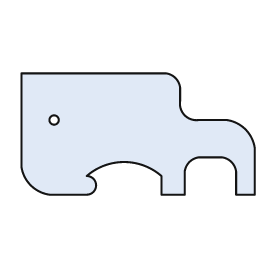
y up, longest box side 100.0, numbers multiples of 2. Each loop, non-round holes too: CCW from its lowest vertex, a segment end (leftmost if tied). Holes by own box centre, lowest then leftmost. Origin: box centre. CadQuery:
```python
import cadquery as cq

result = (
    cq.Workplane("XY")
    .moveTo(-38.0, -26.0)
    .lineTo(-22.0, -26.0)
    .threePointArc((-18.0, -22.0), (-22.0, -18.0))
    .threePointArc((-6.0, -12.0), (10.0, -18.0))
    .lineTo(10.0, -26.0)
    .lineTo(20.0, -26.0)
    .lineTo(20.0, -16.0)
    .threePointArc((22.0, -12.0), (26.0, -10.0))
    .lineTo(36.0, -10.0)
    .threePointArc((40.0, -12.0), (42.0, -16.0))
    .lineTo(42.0, -26.0)
    .lineTo(50.0, -26.0)
    .lineTo(50.0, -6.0)
    .threePointArc((46.0, 2.0), (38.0, 6.0))
    .lineTo(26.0, 6.0)
    .threePointArc((20.0, 8.0), (18.0, 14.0))
    .lineTo(18.0, 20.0)
    .threePointArc((16.0, 24.0), (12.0, 26.0))
    .lineTo(-50.0, 26.0)
    .lineTo(-50.0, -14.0)
    .threePointArc((-46.0, -22.0), (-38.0, -26.0))
    .close()
    .moveTo(-36.0, 6.0)
    .circle(2.0)
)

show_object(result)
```